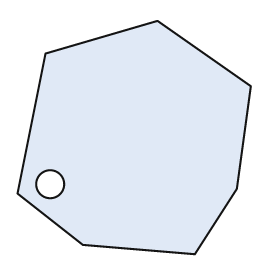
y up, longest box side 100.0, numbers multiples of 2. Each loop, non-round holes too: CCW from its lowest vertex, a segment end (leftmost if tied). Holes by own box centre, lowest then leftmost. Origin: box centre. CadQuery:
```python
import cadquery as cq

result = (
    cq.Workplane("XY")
    .moveTo(26.0, -50.0)
    .lineTo(44.0, -22.0)
    .lineTo(50.0, 22.0)
    .lineTo(10.0, 50.0)
    .lineTo(-38.0, 36.0)
    .lineTo(-50.0, -24.0)
    .lineTo(-22.0, -46.0)
    .close()
    .moveTo(-36.0, -20.0)
    .circle(6.0)
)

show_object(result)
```